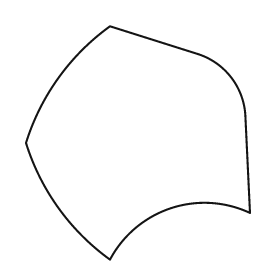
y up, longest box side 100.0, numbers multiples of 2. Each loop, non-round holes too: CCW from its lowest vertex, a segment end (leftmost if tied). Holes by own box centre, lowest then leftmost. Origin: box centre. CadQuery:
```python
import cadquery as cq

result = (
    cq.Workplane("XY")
    .moveTo(-12.0, -50.0)
    .threePointArc((14.0, -28.0), (48.0, -30.0))
    .lineTo(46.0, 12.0)
    .threePointArc((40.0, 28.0), (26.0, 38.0))
    .lineTo(-12.0, 50.0)
    .threePointArc((-34.0, 28.0), (-48.0, 0.0))
    .threePointArc((-34.0, -28.0), (-12.0, -50.0))
    .close()
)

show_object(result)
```